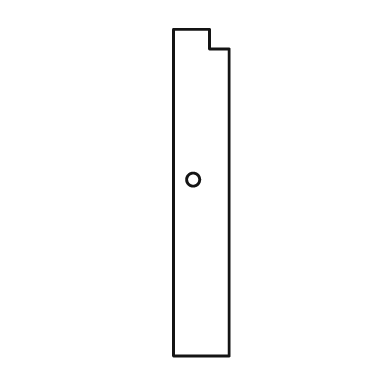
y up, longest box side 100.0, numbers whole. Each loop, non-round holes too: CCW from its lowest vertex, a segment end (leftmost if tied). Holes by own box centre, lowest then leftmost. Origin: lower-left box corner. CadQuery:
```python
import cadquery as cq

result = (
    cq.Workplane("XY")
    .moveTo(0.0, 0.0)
    .lineTo(17.0, 0.0)
    .lineTo(17.0, 94.0)
    .lineTo(11.0, 94.0)
    .lineTo(11.0, 100.0)
    .lineTo(0.0, 100.0)
    .close()
    .moveTo(6.0, 54.0)
    .circle(2.0)
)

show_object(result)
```